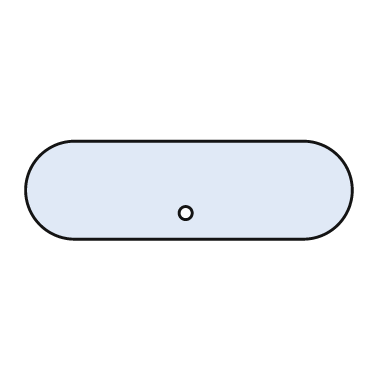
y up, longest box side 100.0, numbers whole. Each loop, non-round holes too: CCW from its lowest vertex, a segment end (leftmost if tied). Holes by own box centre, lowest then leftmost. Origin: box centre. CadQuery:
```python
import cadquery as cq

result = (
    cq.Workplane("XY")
    .moveTo(-35.0, -15.0)
    .lineTo(35.0, -15.0)
    .threePointArc((50.0, 0.0), (35.0, 15.0))
    .lineTo(-35.0, 15.0)
    .threePointArc((-50.0, 0.0), (-35.0, -15.0))
    .close()
    .moveTo(-1.0, -7.0)
    .circle(2.0)
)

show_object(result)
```